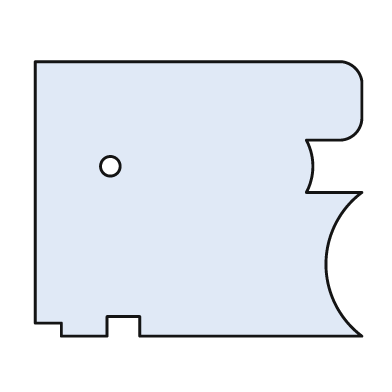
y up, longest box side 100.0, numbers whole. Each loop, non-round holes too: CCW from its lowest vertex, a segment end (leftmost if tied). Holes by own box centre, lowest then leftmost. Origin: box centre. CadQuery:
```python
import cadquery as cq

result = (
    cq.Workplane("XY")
    .moveTo(-42.0, -42.0)
    .lineTo(-28.0, -42.0)
    .lineTo(-28.0, -36.0)
    .lineTo(-18.0, -36.0)
    .lineTo(-18.0, -42.0)
    .lineTo(50.0, -42.0)
    .threePointArc((39.0, -20.0), (50.0, 2.0))
    .lineTo(33.0, 2.0)
    .threePointArc((35.0, 10.0), (33.0, 18.0))
    .lineTo(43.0, 18.0)
    .threePointArc((48.0, 20.0), (50.0, 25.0))
    .lineTo(50.0, 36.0)
    .threePointArc((48.0, 40.0), (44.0, 42.0))
    .lineTo(-50.0, 42.0)
    .lineTo(-50.0, -38.0)
    .lineTo(-42.0, -38.0)
    .close()
    .moveTo(-27.0, 10.0)
    .circle(3.0)
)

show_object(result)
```